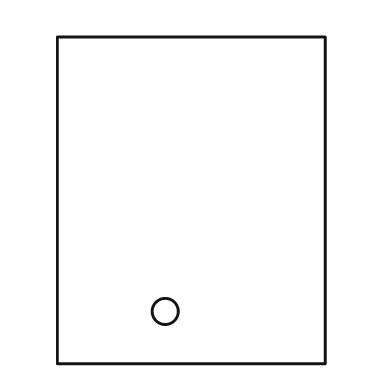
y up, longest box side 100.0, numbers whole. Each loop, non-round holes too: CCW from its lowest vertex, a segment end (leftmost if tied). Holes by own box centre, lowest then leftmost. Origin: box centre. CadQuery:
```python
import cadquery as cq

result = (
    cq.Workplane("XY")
    .moveTo(-41.0, -50.0)
    .lineTo(41.0, -50.0)
    .lineTo(41.0, 50.0)
    .lineTo(-41.0, 50.0)
    .close()
    .moveTo(-8.0, -34.0)
    .circle(4.0)
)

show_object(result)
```